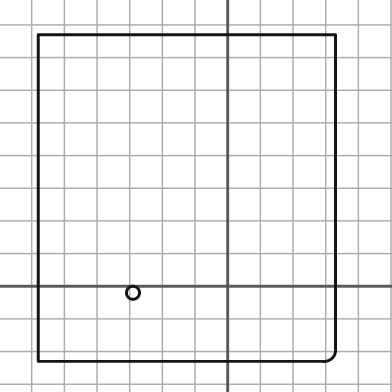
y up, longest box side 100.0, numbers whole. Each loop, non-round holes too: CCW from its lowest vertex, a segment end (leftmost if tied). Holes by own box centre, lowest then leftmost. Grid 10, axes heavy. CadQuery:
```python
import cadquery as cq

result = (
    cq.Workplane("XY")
    .moveTo(-58.0, -23.0)
    .lineTo(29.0, -23.0)
    .threePointArc((32.0, -22.0), (33.0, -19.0))
    .lineTo(33.0, 77.0)
    .lineTo(-58.0, 77.0)
    .close()
    .moveTo(-29.0, -2.0)
    .circle(2.0)
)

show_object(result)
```